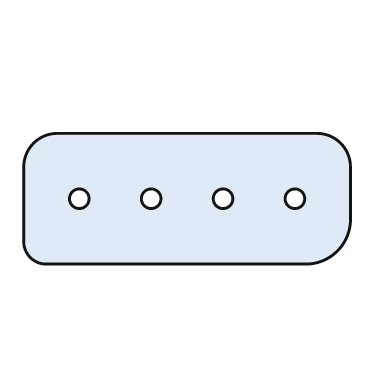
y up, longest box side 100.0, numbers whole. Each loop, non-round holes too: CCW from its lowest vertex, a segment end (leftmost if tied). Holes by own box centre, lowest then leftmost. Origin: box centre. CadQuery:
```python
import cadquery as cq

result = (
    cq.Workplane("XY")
    .moveTo(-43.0, -20.0)
    .lineTo(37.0, -20.0)
    .threePointArc((46.0, -16.0), (50.0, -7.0))
    .lineTo(50.0, 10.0)
    .threePointArc((47.0, 17.0), (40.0, 20.0))
    .lineTo(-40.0, 20.0)
    .threePointArc((-47.0, 17.0), (-50.0, 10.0))
    .lineTo(-50.0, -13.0)
    .threePointArc((-48.0, -18.0), (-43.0, -20.0))
    .close()
    .moveTo(-33.0, 0.0)
    .circle(3.0)
    .moveTo(-11.0, 0.0)
    .circle(3.0)
    .moveTo(11.0, 0.0)
    .circle(3.0)
    .moveTo(33.0, 0.0)
    .circle(3.0)
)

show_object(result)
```